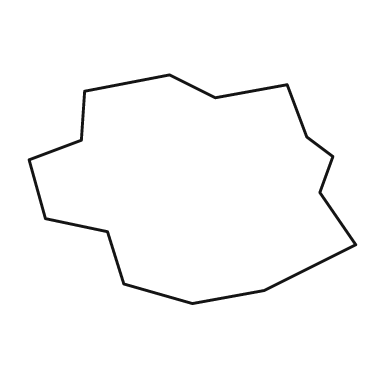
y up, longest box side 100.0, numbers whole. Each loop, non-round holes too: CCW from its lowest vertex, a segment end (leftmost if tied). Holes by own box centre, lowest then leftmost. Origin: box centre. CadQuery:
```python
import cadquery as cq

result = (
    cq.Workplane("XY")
    .moveTo(0.0, -35.0)
    .lineTo(22.0, -31.0)
    .lineTo(50.0, -17.0)
    .lineTo(39.0, -1.0)
    .lineTo(43.0, 10.0)
    .lineTo(35.0, 16.0)
    .lineTo(29.0, 32.0)
    .lineTo(7.0, 28.0)
    .lineTo(-7.0, 35.0)
    .lineTo(-33.0, 30.0)
    .lineTo(-34.0, 15.0)
    .lineTo(-50.0, 9.0)
    .lineTo(-45.0, -9.0)
    .lineTo(-26.0, -13.0)
    .lineTo(-21.0, -29.0)
    .close()
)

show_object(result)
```